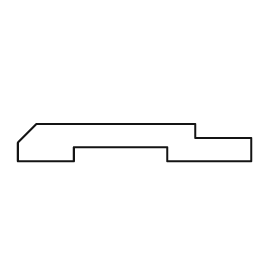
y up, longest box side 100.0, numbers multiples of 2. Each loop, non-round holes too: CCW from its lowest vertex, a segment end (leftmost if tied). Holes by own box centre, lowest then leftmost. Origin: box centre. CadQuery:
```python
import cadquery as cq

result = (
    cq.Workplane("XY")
    .moveTo(-50.0, -8.0)
    .lineTo(-26.0, -8.0)
    .lineTo(-26.0, -2.0)
    .lineTo(14.0, -2.0)
    .lineTo(14.0, -8.0)
    .lineTo(50.0, -8.0)
    .lineTo(50.0, 2.0)
    .lineTo(26.0, 2.0)
    .lineTo(26.0, 8.0)
    .lineTo(-42.0, 8.0)
    .lineTo(-50.0, 0.0)
    .close()
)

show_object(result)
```